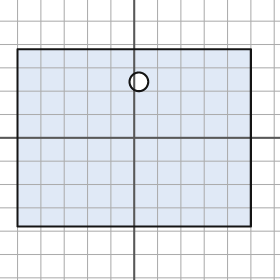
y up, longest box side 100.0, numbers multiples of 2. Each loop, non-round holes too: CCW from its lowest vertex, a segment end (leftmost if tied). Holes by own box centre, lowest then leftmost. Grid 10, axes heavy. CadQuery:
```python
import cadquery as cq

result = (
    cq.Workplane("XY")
    .moveTo(-50.0, -38.0)
    .lineTo(50.0, -38.0)
    .lineTo(50.0, 38.0)
    .lineTo(-50.0, 38.0)
    .close()
    .moveTo(2.0, 24.0)
    .circle(4.0)
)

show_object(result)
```